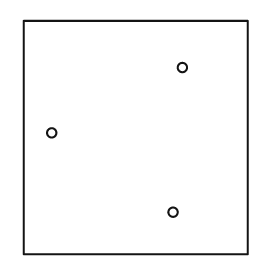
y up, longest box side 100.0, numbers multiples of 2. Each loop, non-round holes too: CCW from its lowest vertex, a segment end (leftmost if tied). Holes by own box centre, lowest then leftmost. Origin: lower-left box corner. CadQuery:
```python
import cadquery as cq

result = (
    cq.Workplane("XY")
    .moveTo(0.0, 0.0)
    .lineTo(96.0, 0.0)
    .lineTo(96.0, 100.0)
    .lineTo(0.0, 100.0)
    .close()
    .moveTo(64.0, 18.0)
    .circle(2.0)
    .moveTo(12.0, 52.0)
    .circle(2.0)
    .moveTo(68.0, 80.0)
    .circle(2.0)
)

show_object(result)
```